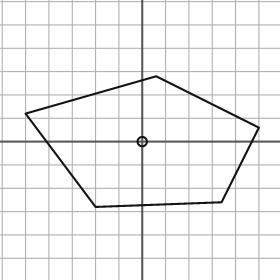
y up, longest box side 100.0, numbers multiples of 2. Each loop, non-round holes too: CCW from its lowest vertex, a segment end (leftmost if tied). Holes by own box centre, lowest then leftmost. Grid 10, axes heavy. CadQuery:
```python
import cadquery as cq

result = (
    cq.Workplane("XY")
    .moveTo(-20.0, -28.0)
    .lineTo(34.0, -26.0)
    .lineTo(50.0, 6.0)
    .lineTo(6.0, 28.0)
    .lineTo(-50.0, 12.0)
    .close()
    .moveTo(0.0, 0.0)
    .circle(2.0)
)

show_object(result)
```